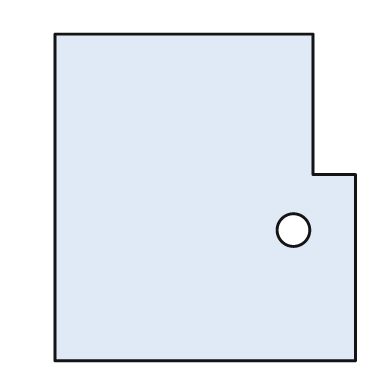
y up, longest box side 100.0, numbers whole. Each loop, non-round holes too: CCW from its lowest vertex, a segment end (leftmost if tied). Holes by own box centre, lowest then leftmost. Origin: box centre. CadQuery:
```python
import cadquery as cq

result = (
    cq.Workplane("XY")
    .moveTo(-46.0, -50.0)
    .lineTo(46.0, -50.0)
    .lineTo(46.0, 7.0)
    .lineTo(33.0, 7.0)
    .lineTo(33.0, 50.0)
    .lineTo(-46.0, 50.0)
    .close()
    .moveTo(27.0, -10.0)
    .circle(5.0)
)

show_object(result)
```